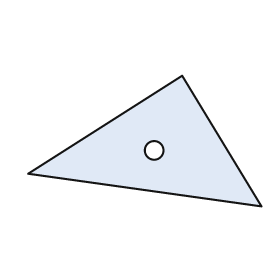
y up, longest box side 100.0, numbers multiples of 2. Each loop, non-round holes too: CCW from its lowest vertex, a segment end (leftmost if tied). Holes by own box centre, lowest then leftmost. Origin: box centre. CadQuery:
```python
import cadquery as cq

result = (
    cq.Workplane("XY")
    .moveTo(50.0, -28.0)
    .lineTo(16.0, 28.0)
    .lineTo(-50.0, -14.0)
    .close()
    .moveTo(4.0, -4.0)
    .circle(4.0)
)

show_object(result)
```